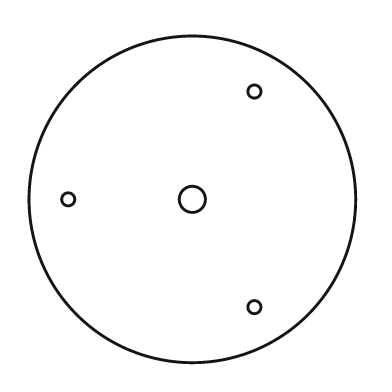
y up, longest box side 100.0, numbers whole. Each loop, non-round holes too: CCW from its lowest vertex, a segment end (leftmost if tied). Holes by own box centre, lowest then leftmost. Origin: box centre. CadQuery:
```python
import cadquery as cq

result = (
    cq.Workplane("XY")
    .moveTo(0.0, 0.0)
    .circle(50.0)
    .moveTo(19.0, -33.0)
    .circle(2.0)
    .moveTo(-38.0, 0.0)
    .circle(2.0)
    .moveTo(0.0, 0.0)
    .circle(4.0)
    .moveTo(19.0, 33.0)
    .circle(2.0)
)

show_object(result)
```